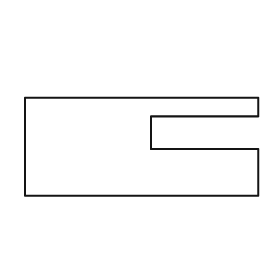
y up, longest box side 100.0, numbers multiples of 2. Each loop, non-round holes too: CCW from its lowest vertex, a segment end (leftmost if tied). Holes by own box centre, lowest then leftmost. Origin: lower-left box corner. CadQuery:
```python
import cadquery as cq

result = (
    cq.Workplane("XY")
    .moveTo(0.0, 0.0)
    .lineTo(100.0, 0.0)
    .lineTo(100.0, 20.0)
    .lineTo(54.0, 20.0)
    .lineTo(54.0, 34.0)
    .lineTo(100.0, 34.0)
    .lineTo(100.0, 42.0)
    .lineTo(0.0, 42.0)
    .close()
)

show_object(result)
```